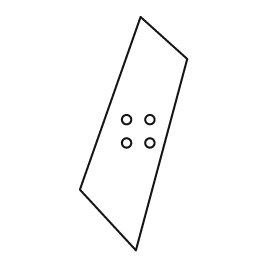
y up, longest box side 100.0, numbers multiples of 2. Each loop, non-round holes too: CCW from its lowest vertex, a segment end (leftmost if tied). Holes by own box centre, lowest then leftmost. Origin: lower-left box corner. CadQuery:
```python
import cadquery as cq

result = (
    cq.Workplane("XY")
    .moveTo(24.0, 0.0)
    .lineTo(46.0, 82.0)
    .lineTo(26.0, 100.0)
    .lineTo(0.0, 26.0)
    .close()
    .moveTo(20.0, 46.0)
    .circle(2.0)
    .moveTo(30.0, 46.0)
    .circle(2.0)
    .moveTo(20.0, 56.0)
    .circle(2.0)
    .moveTo(30.0, 56.0)
    .circle(2.0)
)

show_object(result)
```